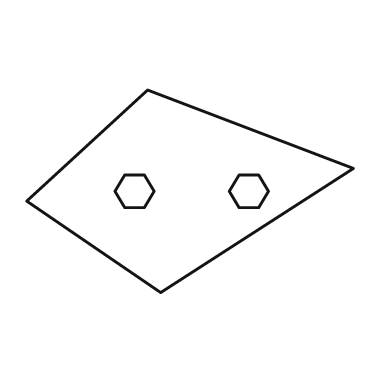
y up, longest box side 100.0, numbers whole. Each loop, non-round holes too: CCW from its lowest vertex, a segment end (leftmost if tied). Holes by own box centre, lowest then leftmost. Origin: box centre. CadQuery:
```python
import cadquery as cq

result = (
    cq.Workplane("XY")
    .moveTo(-9.0, -31.0)
    .lineTo(50.0, 7.0)
    .lineTo(-13.0, 31.0)
    .lineTo(-50.0, -3.0)
    .close()
    .moveTo(-20.0, -5.0)
    .lineTo(-14.0, -5.0)
    .lineTo(-11.0, 0.0)
    .lineTo(-14.0, 5.0)
    .lineTo(-20.0, 5.0)
    .lineTo(-23.0, 0.0)
    .close()
    .moveTo(15.0, -5.0)
    .lineTo(21.0, -5.0)
    .lineTo(24.0, 0.0)
    .lineTo(21.0, 5.0)
    .lineTo(15.0, 5.0)
    .lineTo(12.0, 0.0)
    .close()
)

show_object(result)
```